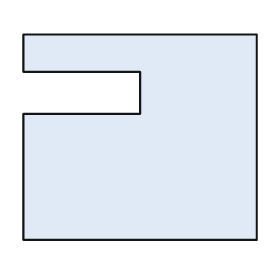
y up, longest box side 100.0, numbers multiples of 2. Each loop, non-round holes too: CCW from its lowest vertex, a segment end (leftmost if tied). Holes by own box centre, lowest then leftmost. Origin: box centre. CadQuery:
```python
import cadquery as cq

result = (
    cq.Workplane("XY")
    .moveTo(-50.0, -44.0)
    .lineTo(50.0, -44.0)
    .lineTo(50.0, 44.0)
    .lineTo(-50.0, 44.0)
    .lineTo(-50.0, 28.0)
    .lineTo(0.0, 28.0)
    .lineTo(0.0, 10.0)
    .lineTo(-50.0, 10.0)
    .close()
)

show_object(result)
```